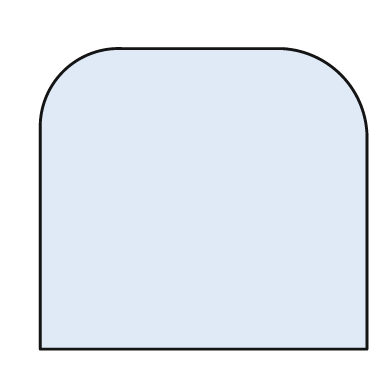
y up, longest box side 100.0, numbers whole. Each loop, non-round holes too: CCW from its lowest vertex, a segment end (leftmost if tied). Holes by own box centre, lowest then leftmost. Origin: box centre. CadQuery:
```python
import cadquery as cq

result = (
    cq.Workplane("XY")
    .moveTo(-50.0, -46.0)
    .lineTo(50.0, -46.0)
    .lineTo(50.0, 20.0)
    .threePointArc((42.0, 38.0), (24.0, 46.0))
    .lineTo(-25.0, 46.0)
    .threePointArc((-43.0, 39.0), (-50.0, 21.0))
    .close()
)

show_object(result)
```